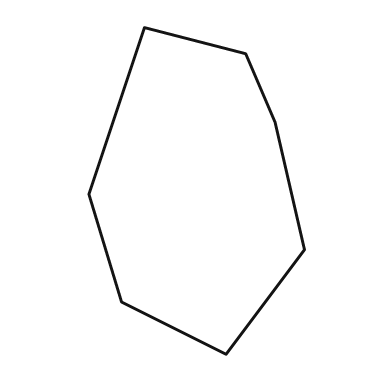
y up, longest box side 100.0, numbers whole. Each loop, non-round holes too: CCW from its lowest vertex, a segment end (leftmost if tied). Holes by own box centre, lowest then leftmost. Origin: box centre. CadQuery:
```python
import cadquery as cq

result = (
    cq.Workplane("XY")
    .moveTo(9.0, -50.0)
    .lineTo(33.0, -18.0)
    .lineTo(24.0, 21.0)
    .lineTo(15.0, 42.0)
    .lineTo(-16.0, 50.0)
    .lineTo(-33.0, -1.0)
    .lineTo(-23.0, -34.0)
    .close()
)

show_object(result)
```